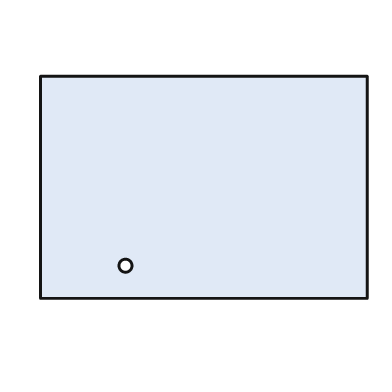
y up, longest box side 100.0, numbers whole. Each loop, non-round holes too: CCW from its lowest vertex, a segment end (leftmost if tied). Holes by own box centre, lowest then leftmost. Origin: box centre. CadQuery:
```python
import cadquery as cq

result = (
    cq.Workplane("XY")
    .moveTo(-50.0, -34.0)
    .lineTo(50.0, -34.0)
    .lineTo(50.0, 34.0)
    .lineTo(-50.0, 34.0)
    .close()
    .moveTo(-24.0, -24.0)
    .circle(2.0)
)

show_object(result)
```